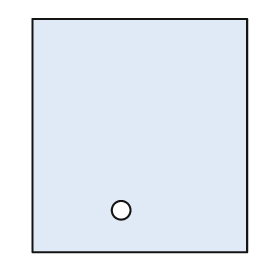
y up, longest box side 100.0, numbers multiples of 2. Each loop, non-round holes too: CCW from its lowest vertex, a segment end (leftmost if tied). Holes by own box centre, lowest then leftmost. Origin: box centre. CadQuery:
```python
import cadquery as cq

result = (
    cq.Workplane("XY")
    .moveTo(-46.0, -50.0)
    .lineTo(46.0, -50.0)
    .lineTo(46.0, 50.0)
    .lineTo(-46.0, 50.0)
    .close()
    .moveTo(-8.0, -32.0)
    .circle(4.0)
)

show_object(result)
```